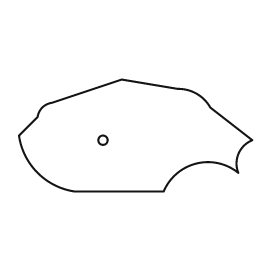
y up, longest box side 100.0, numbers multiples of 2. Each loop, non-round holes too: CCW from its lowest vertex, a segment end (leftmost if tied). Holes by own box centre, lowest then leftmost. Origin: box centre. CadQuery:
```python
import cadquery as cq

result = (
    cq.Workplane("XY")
    .moveTo(-26.0, -24.0)
    .lineTo(12.0, -24.0)
    .threePointArc((26.0, -12.0), (44.0, -16.0))
    .threePointArc((44.0, -8.0), (50.0, -2.0))
    .lineTo(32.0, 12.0)
    .threePointArc((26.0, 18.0), (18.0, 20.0))
    .lineTo(-6.0, 24.0)
    .lineTo(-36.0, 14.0)
    .threePointArc((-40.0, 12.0), (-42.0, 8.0))
    .lineTo(-50.0, 0.0)
    .threePointArc((-42.0, -16.0), (-26.0, -24.0))
    .close()
    .moveTo(-14.0, -2.0)
    .circle(2.0)
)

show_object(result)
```